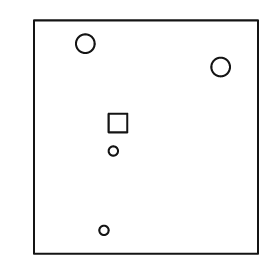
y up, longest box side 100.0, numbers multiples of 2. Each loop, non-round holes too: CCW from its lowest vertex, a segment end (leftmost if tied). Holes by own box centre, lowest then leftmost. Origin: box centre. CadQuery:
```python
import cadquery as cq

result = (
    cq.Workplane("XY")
    .moveTo(-48.0, -50.0)
    .lineTo(48.0, -50.0)
    .lineTo(48.0, 50.0)
    .lineTo(-48.0, 50.0)
    .close()
    .moveTo(-18.0, -40.0)
    .circle(2.0)
    .moveTo(-14.0, -6.0)
    .circle(2.0)
    .moveTo(-16.0, 2.0)
    .lineTo(-8.0, 2.0)
    .lineTo(-8.0, 10.0)
    .lineTo(-16.0, 10.0)
    .close()
    .moveTo(32.0, 30.0)
    .circle(4.0)
    .moveTo(-26.0, 40.0)
    .circle(4.0)
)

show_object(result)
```